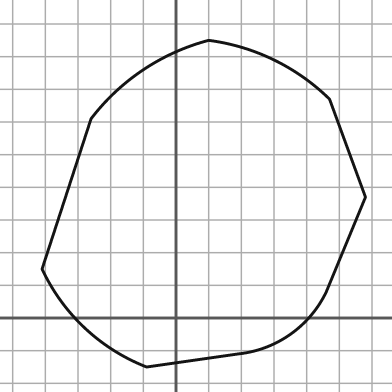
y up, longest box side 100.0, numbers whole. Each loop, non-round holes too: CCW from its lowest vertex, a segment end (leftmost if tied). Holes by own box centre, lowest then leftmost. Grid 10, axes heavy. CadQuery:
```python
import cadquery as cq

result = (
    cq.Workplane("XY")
    .moveTo(-9.0, -15.0)
    .lineTo(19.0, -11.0)
    .threePointArc((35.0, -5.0), (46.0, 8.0))
    .lineTo(58.0, 37.0)
    .lineTo(47.0, 67.0)
    .threePointArc((30.0, 79.0), (10.0, 85.0))
    .threePointArc((-10.0, 76.0), (-26.0, 61.0))
    .lineTo(-41.0, 15.0)
    .threePointArc((-28.0, -3.0), (-9.0, -15.0))
    .close()
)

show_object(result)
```